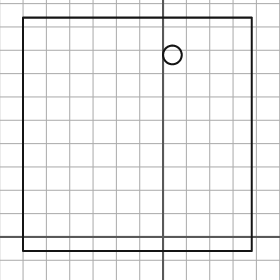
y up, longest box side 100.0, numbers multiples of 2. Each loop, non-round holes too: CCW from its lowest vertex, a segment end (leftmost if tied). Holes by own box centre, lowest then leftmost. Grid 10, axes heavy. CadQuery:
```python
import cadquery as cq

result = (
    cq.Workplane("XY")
    .moveTo(-60.0, -6.0)
    .lineTo(38.0, -6.0)
    .lineTo(38.0, 94.0)
    .lineTo(-60.0, 94.0)
    .close()
    .moveTo(4.0, 78.0)
    .circle(4.0)
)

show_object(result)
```